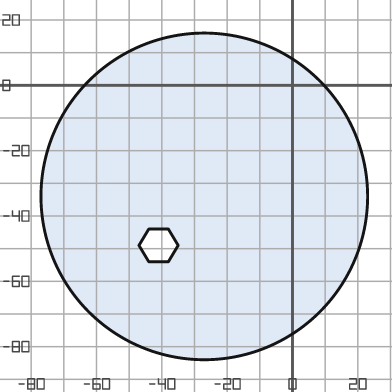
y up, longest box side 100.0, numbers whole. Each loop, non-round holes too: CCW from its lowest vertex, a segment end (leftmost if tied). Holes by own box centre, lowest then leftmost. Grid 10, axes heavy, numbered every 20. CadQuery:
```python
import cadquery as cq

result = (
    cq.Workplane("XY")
    .moveTo(-27.0, -34.0)
    .circle(50.0)
    .moveTo(-44.0, -54.0)
    .lineTo(-38.0, -54.0)
    .lineTo(-35.0, -49.0)
    .lineTo(-38.0, -44.0)
    .lineTo(-44.0, -44.0)
    .lineTo(-47.0, -49.0)
    .close()
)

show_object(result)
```